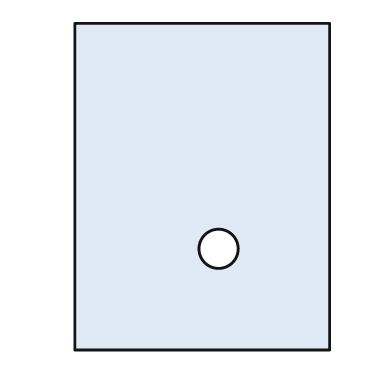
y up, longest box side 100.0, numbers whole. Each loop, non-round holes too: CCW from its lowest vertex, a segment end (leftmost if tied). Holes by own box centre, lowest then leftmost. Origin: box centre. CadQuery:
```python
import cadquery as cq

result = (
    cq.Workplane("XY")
    .moveTo(-39.0, -50.0)
    .lineTo(39.0, -50.0)
    .lineTo(39.0, 50.0)
    .lineTo(-39.0, 50.0)
    .close()
    .moveTo(5.0, -19.0)
    .circle(6.0)
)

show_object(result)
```